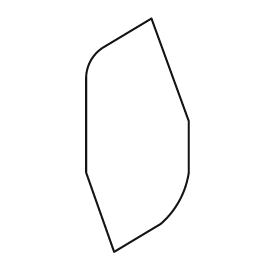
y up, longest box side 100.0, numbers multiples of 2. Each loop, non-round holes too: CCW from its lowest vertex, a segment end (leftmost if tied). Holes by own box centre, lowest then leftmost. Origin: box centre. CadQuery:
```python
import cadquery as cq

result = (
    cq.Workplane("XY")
    .moveTo(-10.0, -50.0)
    .lineTo(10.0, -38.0)
    .threePointArc((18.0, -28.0), (22.0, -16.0))
    .lineTo(22.0, 6.0)
    .lineTo(6.0, 50.0)
    .lineTo(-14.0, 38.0)
    .threePointArc((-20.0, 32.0), (-22.0, 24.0))
    .lineTo(-22.0, -16.0)
    .close()
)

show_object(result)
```